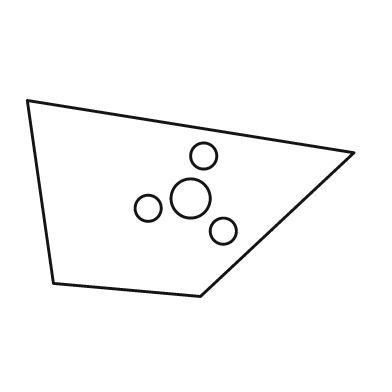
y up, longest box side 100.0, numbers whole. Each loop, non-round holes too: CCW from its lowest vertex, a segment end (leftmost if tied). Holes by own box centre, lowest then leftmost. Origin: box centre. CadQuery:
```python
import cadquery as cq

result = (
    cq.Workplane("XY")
    .moveTo(3.0, -30.0)
    .lineTo(50.0, 14.0)
    .lineTo(-50.0, 30.0)
    .lineTo(-42.0, -26.0)
    .close()
    .moveTo(10.0, -10.0)
    .circle(4.0)
    .moveTo(-13.0, -3.0)
    .circle(4.0)
    .moveTo(0.0, 0.0)
    .circle(6.0)
    .moveTo(4.0, 13.0)
    .circle(4.0)
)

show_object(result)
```